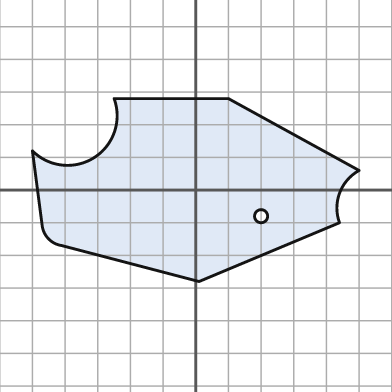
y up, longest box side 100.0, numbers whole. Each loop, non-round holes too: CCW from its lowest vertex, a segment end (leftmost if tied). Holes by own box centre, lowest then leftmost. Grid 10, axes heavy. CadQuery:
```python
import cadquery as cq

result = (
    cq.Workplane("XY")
    .moveTo(1.0, -28.0)
    .lineTo(44.0, -10.0)
    .threePointArc((44.0, -1.0), (50.0, 6.0))
    .lineTo(10.0, 28.0)
    .lineTo(-25.0, 28.0)
    .threePointArc((-31.0, 10.0), (-50.0, 12.0))
    .lineTo(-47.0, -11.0)
    .threePointArc((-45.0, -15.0), (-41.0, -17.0))
    .close()
    .moveTo(20.0, -8.0)
    .circle(2.0)
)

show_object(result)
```